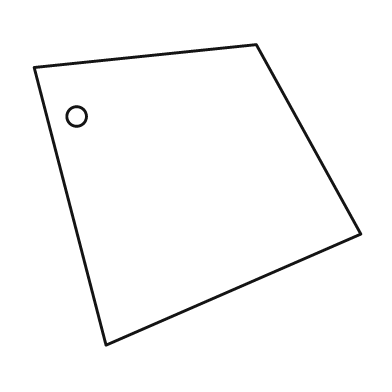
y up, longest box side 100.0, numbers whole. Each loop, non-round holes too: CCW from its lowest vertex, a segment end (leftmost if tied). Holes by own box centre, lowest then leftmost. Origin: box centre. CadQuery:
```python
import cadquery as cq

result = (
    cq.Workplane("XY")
    .moveTo(-28.0, -46.0)
    .lineTo(50.0, -12.0)
    .lineTo(18.0, 46.0)
    .lineTo(-50.0, 39.0)
    .close()
    .moveTo(-37.0, 24.0)
    .circle(3.0)
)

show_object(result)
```